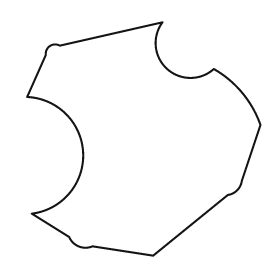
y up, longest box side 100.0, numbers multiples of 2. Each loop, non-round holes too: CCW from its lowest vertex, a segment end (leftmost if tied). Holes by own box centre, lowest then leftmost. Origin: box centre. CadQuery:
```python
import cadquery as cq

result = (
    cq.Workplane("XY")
    .moveTo(4.0, -50.0)
    .lineTo(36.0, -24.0)
    .threePointArc((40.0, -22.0), (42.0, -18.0))
    .lineTo(50.0, 6.0)
    .threePointArc((42.0, 20.0), (30.0, 30.0))
    .threePointArc((10.0, 30.0), (8.0, 50.0))
    .lineTo(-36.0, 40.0)
    .threePointArc((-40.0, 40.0), (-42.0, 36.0))
    .lineTo(-50.0, 18.0)
    .threePointArc((-26.0, -6.0), (-48.0, -32.0))
    .lineTo(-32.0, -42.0)
    .threePointArc((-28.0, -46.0), (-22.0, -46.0))
    .close()
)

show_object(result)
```